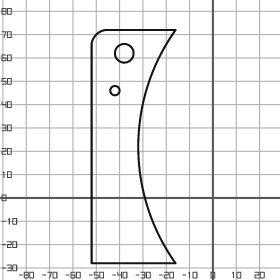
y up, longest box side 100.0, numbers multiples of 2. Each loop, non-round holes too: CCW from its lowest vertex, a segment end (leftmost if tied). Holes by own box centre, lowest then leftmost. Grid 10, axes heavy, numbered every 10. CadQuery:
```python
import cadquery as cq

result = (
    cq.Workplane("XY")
    .moveTo(-52.0, -28.0)
    .lineTo(-16.0, -28.0)
    .threePointArc((-32.0, 22.0), (-16.0, 72.0))
    .lineTo(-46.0, 72.0)
    .threePointArc((-50.0, 70.0), (-52.0, 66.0))
    .close()
    .moveTo(-42.0, 46.0)
    .circle(2.0)
    .moveTo(-38.0, 62.0)
    .circle(4.0)
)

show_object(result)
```